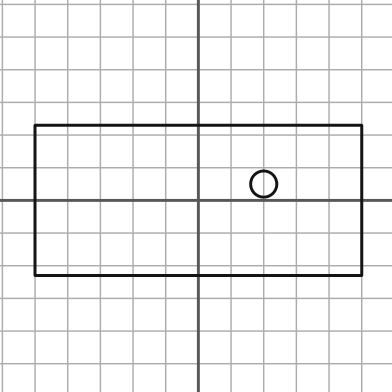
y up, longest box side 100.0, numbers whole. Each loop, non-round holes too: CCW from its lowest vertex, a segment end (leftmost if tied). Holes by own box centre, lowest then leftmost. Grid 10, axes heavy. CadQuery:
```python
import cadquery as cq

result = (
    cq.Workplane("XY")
    .moveTo(-50.0, -23.0)
    .lineTo(50.0, -23.0)
    .lineTo(50.0, 23.0)
    .lineTo(-50.0, 23.0)
    .close()
    .moveTo(20.0, 5.0)
    .circle(4.0)
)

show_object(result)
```